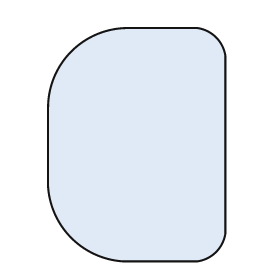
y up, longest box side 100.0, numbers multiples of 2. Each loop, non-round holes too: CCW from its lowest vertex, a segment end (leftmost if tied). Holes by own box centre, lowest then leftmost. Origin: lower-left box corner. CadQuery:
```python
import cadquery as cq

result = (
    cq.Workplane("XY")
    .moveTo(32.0, 0.0)
    .lineTo(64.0, 0.0)
    .threePointArc((72.0, 4.0), (76.0, 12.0))
    .lineTo(76.0, 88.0)
    .threePointArc((72.0, 96.0), (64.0, 100.0))
    .lineTo(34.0, 100.0)
    .threePointArc((10.0, 90.0), (0.0, 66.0))
    .lineTo(0.0, 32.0)
    .threePointArc((10.0, 10.0), (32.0, 0.0))
    .close()
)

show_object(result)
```